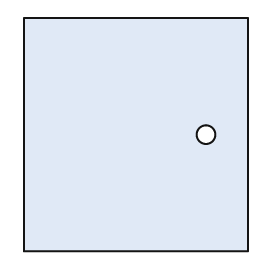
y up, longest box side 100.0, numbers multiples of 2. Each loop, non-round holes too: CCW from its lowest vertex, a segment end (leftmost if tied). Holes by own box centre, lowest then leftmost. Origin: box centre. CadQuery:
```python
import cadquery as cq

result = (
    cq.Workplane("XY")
    .moveTo(-48.0, -50.0)
    .lineTo(48.0, -50.0)
    .lineTo(48.0, 50.0)
    .lineTo(-48.0, 50.0)
    .close()
    .moveTo(30.0, 0.0)
    .circle(4.0)
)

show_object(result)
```